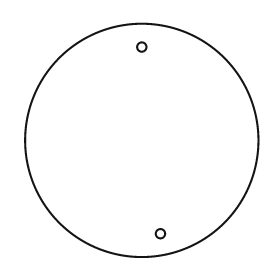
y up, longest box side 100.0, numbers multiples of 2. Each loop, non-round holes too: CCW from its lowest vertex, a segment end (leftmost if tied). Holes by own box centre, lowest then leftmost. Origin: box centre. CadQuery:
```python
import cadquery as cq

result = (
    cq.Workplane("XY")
    .moveTo(0.0, 0.0)
    .circle(50.0)
    .moveTo(8.0, -40.0)
    .circle(2.0)
    .moveTo(0.0, 40.0)
    .circle(2.0)
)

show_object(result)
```